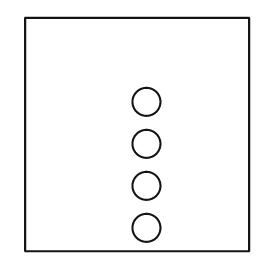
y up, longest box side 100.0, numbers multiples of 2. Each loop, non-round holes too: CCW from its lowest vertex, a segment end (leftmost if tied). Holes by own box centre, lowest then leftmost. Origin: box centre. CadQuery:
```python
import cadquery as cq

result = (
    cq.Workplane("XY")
    .moveTo(-48.0, -50.0)
    .lineTo(48.0, -50.0)
    .lineTo(48.0, 50.0)
    .lineTo(-48.0, 50.0)
    .close()
    .moveTo(4.0, -40.0)
    .circle(6.0)
    .moveTo(4.0, -22.0)
    .circle(6.0)
    .moveTo(4.0, -4.0)
    .circle(6.0)
    .moveTo(4.0, 14.0)
    .circle(6.0)
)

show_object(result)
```